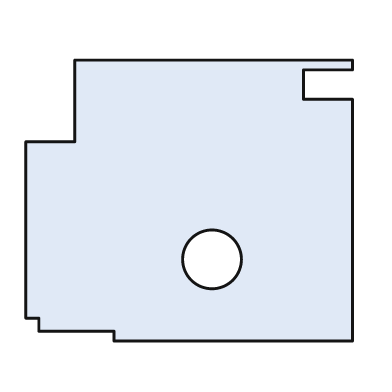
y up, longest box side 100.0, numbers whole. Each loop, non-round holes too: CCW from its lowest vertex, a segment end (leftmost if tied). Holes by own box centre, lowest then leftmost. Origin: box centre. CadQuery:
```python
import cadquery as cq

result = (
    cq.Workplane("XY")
    .moveTo(-23.0, -43.0)
    .lineTo(50.0, -43.0)
    .lineTo(50.0, 31.0)
    .lineTo(35.0, 31.0)
    .lineTo(35.0, 40.0)
    .lineTo(50.0, 40.0)
    .lineTo(50.0, 43.0)
    .lineTo(-35.0, 43.0)
    .lineTo(-35.0, 18.0)
    .lineTo(-50.0, 18.0)
    .lineTo(-50.0, -36.0)
    .lineTo(-46.0, -36.0)
    .lineTo(-46.0, -40.0)
    .lineTo(-23.0, -40.0)
    .close()
    .moveTo(7.0, -18.0)
    .circle(9.0)
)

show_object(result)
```